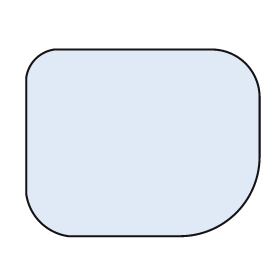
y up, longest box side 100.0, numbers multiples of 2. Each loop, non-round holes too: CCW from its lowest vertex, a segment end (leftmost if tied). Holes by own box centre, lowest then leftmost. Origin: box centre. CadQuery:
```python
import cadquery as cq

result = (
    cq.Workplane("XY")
    .moveTo(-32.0, -40.0)
    .lineTo(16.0, -40.0)
    .threePointArc((40.0, -30.0), (50.0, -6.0))
    .lineTo(50.0, 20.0)
    .threePointArc((44.0, 34.0), (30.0, 40.0))
    .lineTo(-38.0, 40.0)
    .threePointArc((-46.0, 36.0), (-50.0, 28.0))
    .lineTo(-50.0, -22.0)
    .threePointArc((-44.0, -34.0), (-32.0, -40.0))
    .close()
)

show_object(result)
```